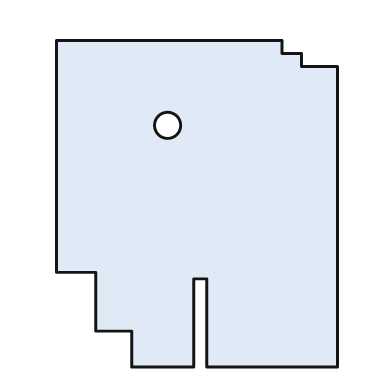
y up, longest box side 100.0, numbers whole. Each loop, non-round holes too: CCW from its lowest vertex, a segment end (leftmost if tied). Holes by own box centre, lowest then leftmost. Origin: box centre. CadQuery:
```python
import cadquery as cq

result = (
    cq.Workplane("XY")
    .moveTo(-20.0, -50.0)
    .lineTo(-1.0, -50.0)
    .lineTo(-1.0, -23.0)
    .lineTo(3.0, -23.0)
    .lineTo(3.0, -50.0)
    .lineTo(43.0, -50.0)
    .lineTo(43.0, 42.0)
    .lineTo(32.0, 42.0)
    .lineTo(32.0, 46.0)
    .lineTo(26.0, 46.0)
    .lineTo(26.0, 50.0)
    .lineTo(-43.0, 50.0)
    .lineTo(-43.0, -21.0)
    .lineTo(-31.0, -21.0)
    .lineTo(-31.0, -39.0)
    .lineTo(-20.0, -39.0)
    .close()
    .moveTo(-9.0, 24.0)
    .circle(4.0)
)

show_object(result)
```